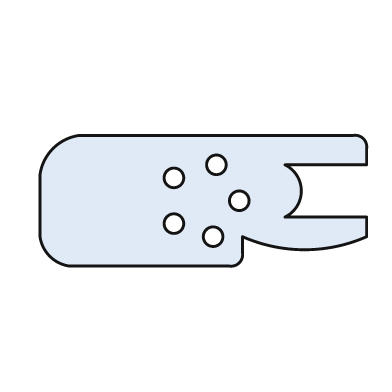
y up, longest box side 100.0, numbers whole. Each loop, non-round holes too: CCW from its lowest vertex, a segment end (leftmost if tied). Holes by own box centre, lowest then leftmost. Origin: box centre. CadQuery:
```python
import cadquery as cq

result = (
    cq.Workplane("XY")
    .moveTo(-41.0, -20.0)
    .lineTo(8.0, -20.0)
    .threePointArc((11.0, -19.0), (12.0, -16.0))
    .lineTo(12.0, -11.0)
    .threePointArc((31.0, -15.0), (50.0, -11.0))
    .lineTo(50.0, -5.0)
    .lineTo(25.0, -5.0)
    .threePointArc((30.0, 3.0), (25.0, 11.0))
    .lineTo(50.0, 11.0)
    .lineTo(50.0, 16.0)
    .threePointArc((49.0, 19.0), (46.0, 20.0))
    .lineTo(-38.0, 20.0)
    .threePointArc((-46.0, 16.0), (-50.0, 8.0))
    .lineTo(-50.0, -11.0)
    .threePointArc((-47.0, -17.0), (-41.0, -20.0))
    .close()
    .moveTo(3.0, -11.0)
    .circle(3.0)
    .moveTo(-9.0, -7.0)
    .circle(3.0)
    .moveTo(11.0, 0.0)
    .circle(3.0)
    .moveTo(-9.0, 7.0)
    .circle(3.0)
    .moveTo(4.0, 11.0)
    .circle(3.0)
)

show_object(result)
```